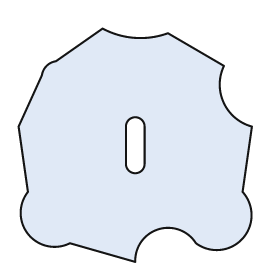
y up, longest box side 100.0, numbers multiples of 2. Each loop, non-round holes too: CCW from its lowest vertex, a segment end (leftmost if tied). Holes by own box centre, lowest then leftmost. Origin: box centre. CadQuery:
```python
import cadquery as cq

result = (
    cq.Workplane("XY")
    .moveTo(0.0, -50.0)
    .threePointArc((10.0, -36.0), (26.0, -42.0))
    .threePointArc((46.0, -40.0), (46.0, -20.0))
    .lineTo(50.0, 8.0)
    .threePointArc((38.0, 18.0), (38.0, 34.0))
    .lineTo(14.0, 48.0)
    .threePointArc((0.0, 46.0), (-14.0, 50.0))
    .lineTo(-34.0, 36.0)
    .threePointArc((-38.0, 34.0), (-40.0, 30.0))
    .lineTo(-50.0, 8.0)
    .lineTo(-46.0, -20.0)
    .threePointArc((-46.0, -38.0), (-28.0, -42.0))
    .close()
    .moveTo(-4.0, -8.0)
    .threePointArc((0.0, -12.0), (4.0, -8.0))
    .lineTo(4.0, 8.0)
    .threePointArc((0.0, 12.0), (-4.0, 8.0))
    .close()
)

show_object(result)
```